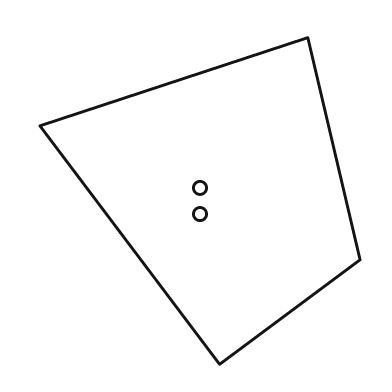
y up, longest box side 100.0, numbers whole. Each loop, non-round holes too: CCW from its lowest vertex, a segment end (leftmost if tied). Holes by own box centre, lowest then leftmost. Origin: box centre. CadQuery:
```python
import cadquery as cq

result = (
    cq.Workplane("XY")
    .moveTo(6.0, -50.0)
    .lineTo(49.0, -18.0)
    .lineTo(33.0, 50.0)
    .lineTo(-49.0, 23.0)
    .close()
    .moveTo(0.0, -4.0)
    .circle(2.0)
    .moveTo(0.0, 4.0)
    .circle(2.0)
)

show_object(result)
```